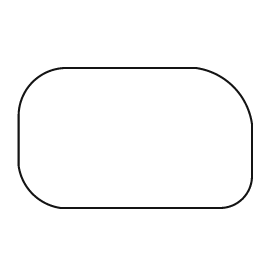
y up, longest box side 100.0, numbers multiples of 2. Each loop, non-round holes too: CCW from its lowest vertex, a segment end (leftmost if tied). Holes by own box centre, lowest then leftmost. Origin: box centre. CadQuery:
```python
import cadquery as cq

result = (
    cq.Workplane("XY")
    .moveTo(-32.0, -30.0)
    .lineTo(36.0, -30.0)
    .threePointArc((46.0, -26.0), (50.0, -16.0))
    .lineTo(50.0, 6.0)
    .threePointArc((42.0, 22.0), (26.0, 30.0))
    .lineTo(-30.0, 30.0)
    .threePointArc((-44.0, 24.0), (-50.0, 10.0))
    .lineTo(-50.0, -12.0)
    .threePointArc((-44.0, -24.0), (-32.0, -30.0))
    .close()
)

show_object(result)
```